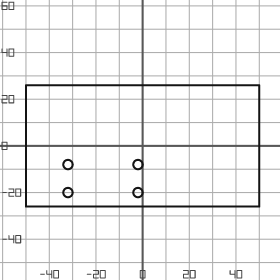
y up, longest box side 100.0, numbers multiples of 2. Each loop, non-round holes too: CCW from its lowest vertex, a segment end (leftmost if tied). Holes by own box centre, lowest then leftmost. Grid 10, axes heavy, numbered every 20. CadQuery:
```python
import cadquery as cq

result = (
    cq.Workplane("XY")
    .moveTo(-50.0, -26.0)
    .lineTo(50.0, -26.0)
    .lineTo(50.0, 26.0)
    .lineTo(-50.0, 26.0)
    .close()
    .moveTo(-32.0, -20.0)
    .circle(2.0)
    .moveTo(-2.0, -20.0)
    .circle(2.0)
    .moveTo(-32.0, -8.0)
    .circle(2.0)
    .moveTo(-2.0, -8.0)
    .circle(2.0)
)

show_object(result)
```